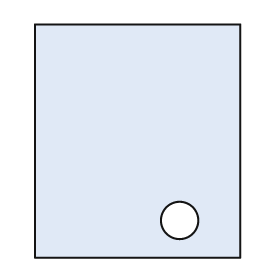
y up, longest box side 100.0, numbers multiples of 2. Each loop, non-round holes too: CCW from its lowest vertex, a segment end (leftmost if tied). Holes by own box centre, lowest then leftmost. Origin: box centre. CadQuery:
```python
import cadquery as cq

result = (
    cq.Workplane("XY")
    .moveTo(-44.0, -50.0)
    .lineTo(44.0, -50.0)
    .lineTo(44.0, 50.0)
    .lineTo(-44.0, 50.0)
    .close()
    .moveTo(18.0, -34.0)
    .circle(8.0)
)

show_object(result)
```